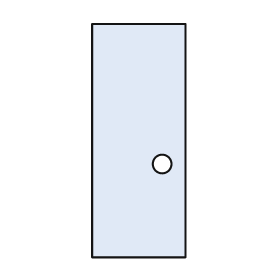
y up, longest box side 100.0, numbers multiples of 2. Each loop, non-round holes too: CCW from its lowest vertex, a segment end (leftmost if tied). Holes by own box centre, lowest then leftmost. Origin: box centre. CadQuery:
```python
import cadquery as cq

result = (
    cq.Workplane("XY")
    .moveTo(-20.0, -50.0)
    .lineTo(20.0, -50.0)
    .lineTo(20.0, 50.0)
    .lineTo(-20.0, 50.0)
    .close()
    .moveTo(10.0, -10.0)
    .circle(4.0)
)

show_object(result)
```